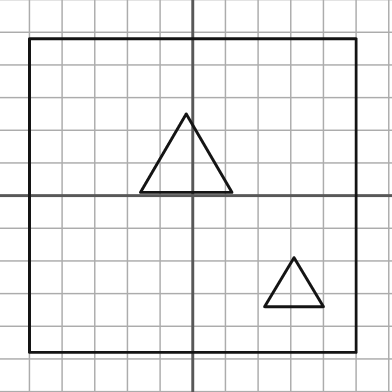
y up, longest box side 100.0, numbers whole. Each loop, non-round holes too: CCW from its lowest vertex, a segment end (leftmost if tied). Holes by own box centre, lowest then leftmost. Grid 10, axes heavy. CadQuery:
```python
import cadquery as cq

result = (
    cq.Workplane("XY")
    .moveTo(-50.0, -48.0)
    .lineTo(50.0, -48.0)
    .lineTo(50.0, 48.0)
    .lineTo(-50.0, 48.0)
    .close()
    .moveTo(22.0, -34.0)
    .lineTo(40.0, -34.0)
    .lineTo(31.0, -19.0)
    .close()
    .moveTo(-16.0, 1.0)
    .lineTo(12.0, 1.0)
    .lineTo(-2.0, 25.0)
    .close()
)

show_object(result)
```